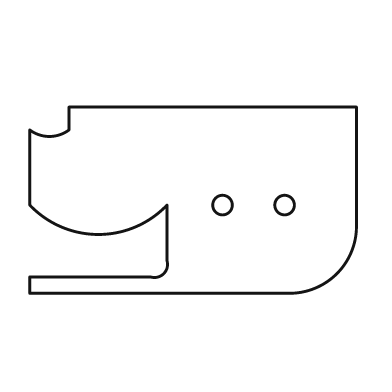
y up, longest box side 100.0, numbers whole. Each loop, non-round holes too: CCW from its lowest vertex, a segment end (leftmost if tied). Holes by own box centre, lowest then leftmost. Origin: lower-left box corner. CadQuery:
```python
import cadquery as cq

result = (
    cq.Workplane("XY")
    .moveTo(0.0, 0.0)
    .lineTo(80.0, 0.0)
    .threePointArc((94.0, 6.0), (100.0, 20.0))
    .lineTo(100.0, 57.0)
    .lineTo(12.0, 57.0)
    .lineTo(12.0, 50.0)
    .threePointArc((6.0, 48.0), (0.0, 50.0))
    .lineTo(0.0, 27.0)
    .threePointArc((21.0, 18.0), (42.0, 27.0))
    .lineTo(42.0, 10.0)
    .threePointArc((41.0, 6.0), (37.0, 5.0))
    .lineTo(0.0, 5.0)
    .close()
    .moveTo(59.0, 27.0)
    .circle(3.0)
    .moveTo(78.0, 27.0)
    .circle(3.0)
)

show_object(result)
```